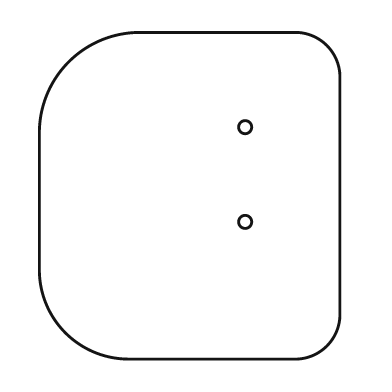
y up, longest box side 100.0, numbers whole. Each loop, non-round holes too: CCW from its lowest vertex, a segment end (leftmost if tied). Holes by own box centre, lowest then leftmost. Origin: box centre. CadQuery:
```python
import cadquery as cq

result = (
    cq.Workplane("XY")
    .moveTo(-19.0, -50.0)
    .lineTo(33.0, -50.0)
    .threePointArc((42.0, -46.0), (46.0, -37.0))
    .lineTo(46.0, 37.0)
    .threePointArc((42.0, 46.0), (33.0, 50.0))
    .lineTo(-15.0, 50.0)
    .threePointArc((-37.0, 41.0), (-46.0, 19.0))
    .lineTo(-46.0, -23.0)
    .threePointArc((-38.0, -42.0), (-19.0, -50.0))
    .close()
    .moveTo(17.0, -8.0)
    .circle(2.0)
    .moveTo(17.0, 21.0)
    .circle(2.0)
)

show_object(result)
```